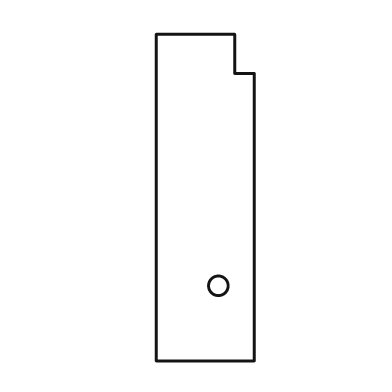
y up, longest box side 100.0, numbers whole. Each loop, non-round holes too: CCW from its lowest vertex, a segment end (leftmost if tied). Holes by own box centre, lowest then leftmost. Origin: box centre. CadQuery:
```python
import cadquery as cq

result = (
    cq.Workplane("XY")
    .moveTo(-15.0, -50.0)
    .lineTo(15.0, -50.0)
    .lineTo(15.0, 38.0)
    .lineTo(9.0, 38.0)
    .lineTo(9.0, 50.0)
    .lineTo(-15.0, 50.0)
    .close()
    .moveTo(4.0, -27.0)
    .circle(3.0)
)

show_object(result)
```